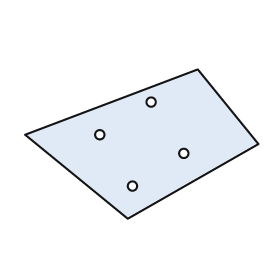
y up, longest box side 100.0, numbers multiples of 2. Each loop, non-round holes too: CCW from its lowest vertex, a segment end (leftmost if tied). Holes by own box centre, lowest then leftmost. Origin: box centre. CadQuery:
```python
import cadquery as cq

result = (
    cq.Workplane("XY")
    .moveTo(-6.0, -32.0)
    .lineTo(50.0, 0.0)
    .lineTo(24.0, 32.0)
    .lineTo(-50.0, 4.0)
    .close()
    .moveTo(-4.0, -18.0)
    .circle(2.0)
    .moveTo(18.0, -4.0)
    .circle(2.0)
    .moveTo(-18.0, 4.0)
    .circle(2.0)
    .moveTo(4.0, 18.0)
    .circle(2.0)
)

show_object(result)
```